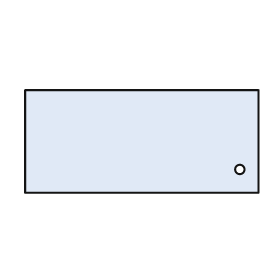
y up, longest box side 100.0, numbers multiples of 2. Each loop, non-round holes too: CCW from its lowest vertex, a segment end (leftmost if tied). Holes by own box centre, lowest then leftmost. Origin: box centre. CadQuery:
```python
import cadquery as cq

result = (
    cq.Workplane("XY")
    .moveTo(-50.0, -22.0)
    .lineTo(50.0, -22.0)
    .lineTo(50.0, 22.0)
    .lineTo(-50.0, 22.0)
    .close()
    .moveTo(42.0, -12.0)
    .circle(2.0)
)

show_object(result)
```